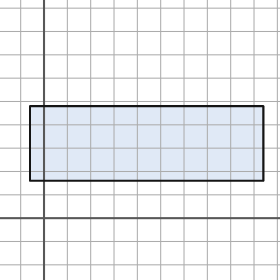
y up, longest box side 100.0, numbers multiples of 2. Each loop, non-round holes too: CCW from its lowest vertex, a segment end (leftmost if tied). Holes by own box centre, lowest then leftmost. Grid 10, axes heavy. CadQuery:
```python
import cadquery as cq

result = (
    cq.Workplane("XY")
    .moveTo(-6.0, 16.0)
    .lineTo(94.0, 16.0)
    .lineTo(94.0, 48.0)
    .lineTo(-6.0, 48.0)
    .close()
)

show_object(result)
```